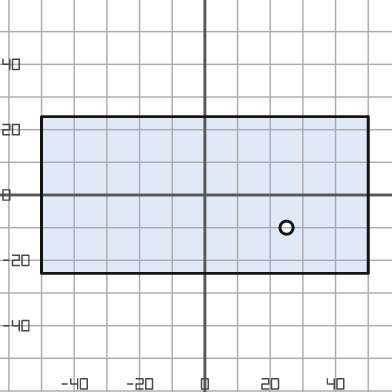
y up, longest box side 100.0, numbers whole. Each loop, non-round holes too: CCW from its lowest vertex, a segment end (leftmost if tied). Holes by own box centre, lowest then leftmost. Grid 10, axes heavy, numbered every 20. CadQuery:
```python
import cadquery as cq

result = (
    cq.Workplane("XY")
    .moveTo(-50.0, -24.0)
    .lineTo(50.0, -24.0)
    .lineTo(50.0, 24.0)
    .lineTo(-50.0, 24.0)
    .close()
    .moveTo(25.0, -10.0)
    .circle(2.0)
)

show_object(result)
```